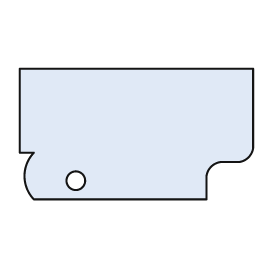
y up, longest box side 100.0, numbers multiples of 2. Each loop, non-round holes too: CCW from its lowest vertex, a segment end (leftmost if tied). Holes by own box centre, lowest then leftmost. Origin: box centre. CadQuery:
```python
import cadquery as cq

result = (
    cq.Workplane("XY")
    .moveTo(-44.0, -28.0)
    .lineTo(30.0, -28.0)
    .lineTo(30.0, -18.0)
    .threePointArc((32.0, -14.0), (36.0, -12.0))
    .lineTo(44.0, -12.0)
    .threePointArc((48.0, -10.0), (50.0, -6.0))
    .lineTo(50.0, 28.0)
    .lineTo(-50.0, 28.0)
    .lineTo(-50.0, -8.0)
    .lineTo(-44.0, -8.0)
    .threePointArc((-48.0, -18.0), (-44.0, -28.0))
    .close()
    .moveTo(-26.0, -20.0)
    .circle(4.0)
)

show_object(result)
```